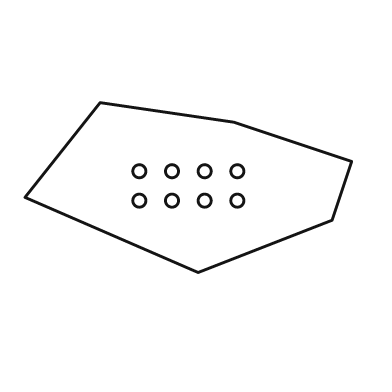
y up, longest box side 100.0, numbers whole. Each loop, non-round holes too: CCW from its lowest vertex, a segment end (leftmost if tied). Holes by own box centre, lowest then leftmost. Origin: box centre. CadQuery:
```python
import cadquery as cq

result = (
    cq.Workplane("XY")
    .moveTo(3.0, -26.0)
    .lineTo(44.0, -10.0)
    .lineTo(50.0, 8.0)
    .lineTo(14.0, 20.0)
    .lineTo(-27.0, 26.0)
    .lineTo(-50.0, -3.0)
    .close()
    .moveTo(-15.0, -4.0)
    .circle(2.0)
    .moveTo(-5.0, -4.0)
    .circle(2.0)
    .moveTo(5.0, -4.0)
    .circle(2.0)
    .moveTo(15.0, -4.0)
    .circle(2.0)
    .moveTo(-15.0, 5.0)
    .circle(2.0)
    .moveTo(-5.0, 5.0)
    .circle(2.0)
    .moveTo(5.0, 5.0)
    .circle(2.0)
    .moveTo(15.0, 5.0)
    .circle(2.0)
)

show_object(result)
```